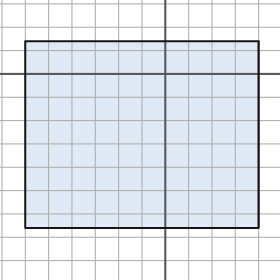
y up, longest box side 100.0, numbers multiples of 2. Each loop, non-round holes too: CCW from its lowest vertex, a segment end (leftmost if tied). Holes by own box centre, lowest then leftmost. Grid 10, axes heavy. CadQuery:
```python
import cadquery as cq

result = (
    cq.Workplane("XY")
    .moveTo(-60.0, -66.0)
    .lineTo(40.0, -66.0)
    .lineTo(40.0, 14.0)
    .lineTo(-60.0, 14.0)
    .close()
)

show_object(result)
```